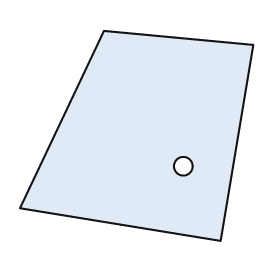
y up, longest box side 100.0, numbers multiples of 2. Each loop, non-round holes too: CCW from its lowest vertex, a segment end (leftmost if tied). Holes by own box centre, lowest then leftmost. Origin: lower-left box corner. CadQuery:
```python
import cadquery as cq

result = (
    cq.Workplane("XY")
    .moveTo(86.0, 0.0)
    .lineTo(100.0, 84.0)
    .lineTo(36.0, 90.0)
    .lineTo(0.0, 14.0)
    .close()
    .moveTo(70.0, 32.0)
    .circle(4.0)
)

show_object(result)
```